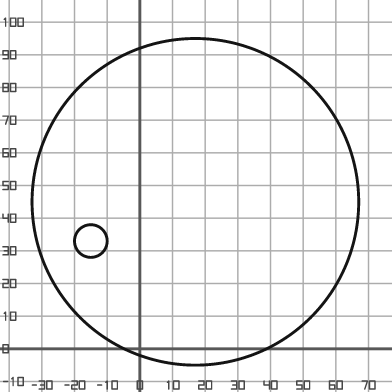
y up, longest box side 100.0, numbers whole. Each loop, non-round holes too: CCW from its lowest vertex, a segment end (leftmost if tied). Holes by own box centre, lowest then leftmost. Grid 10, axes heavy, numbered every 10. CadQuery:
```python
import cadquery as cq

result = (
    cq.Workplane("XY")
    .moveTo(17.0, 45.0)
    .circle(50.0)
    .moveTo(-15.0, 33.0)
    .circle(5.0)
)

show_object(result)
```